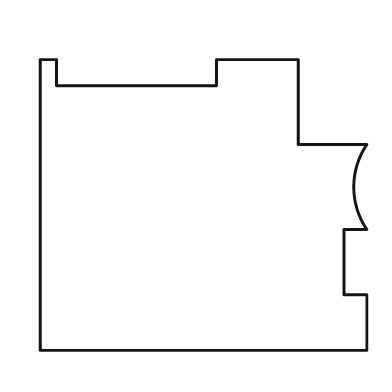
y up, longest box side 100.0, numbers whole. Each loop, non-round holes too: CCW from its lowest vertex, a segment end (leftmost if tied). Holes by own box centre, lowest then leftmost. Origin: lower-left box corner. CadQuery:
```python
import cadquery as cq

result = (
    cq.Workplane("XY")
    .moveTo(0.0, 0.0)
    .lineTo(100.0, 0.0)
    .lineTo(100.0, 17.0)
    .lineTo(93.0, 17.0)
    .lineTo(93.0, 37.0)
    .lineTo(100.0, 37.0)
    .threePointArc((96.0, 50.0), (100.0, 63.0))
    .lineTo(79.0, 63.0)
    .lineTo(79.0, 89.0)
    .lineTo(54.0, 89.0)
    .lineTo(54.0, 81.0)
    .lineTo(5.0, 81.0)
    .lineTo(5.0, 89.0)
    .lineTo(0.0, 89.0)
    .close()
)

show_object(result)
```